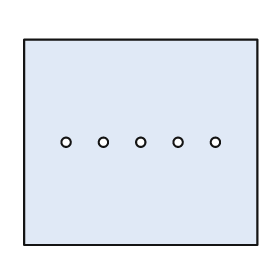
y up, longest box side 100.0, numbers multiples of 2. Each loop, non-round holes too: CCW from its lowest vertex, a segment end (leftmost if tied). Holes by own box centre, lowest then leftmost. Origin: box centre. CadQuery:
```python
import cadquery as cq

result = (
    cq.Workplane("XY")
    .moveTo(-50.0, -44.0)
    .lineTo(50.0, -44.0)
    .lineTo(50.0, 44.0)
    .lineTo(-50.0, 44.0)
    .close()
    .moveTo(-32.0, 0.0)
    .circle(2.0)
    .moveTo(-16.0, 0.0)
    .circle(2.0)
    .moveTo(0.0, 0.0)
    .circle(2.0)
    .moveTo(16.0, 0.0)
    .circle(2.0)
    .moveTo(32.0, 0.0)
    .circle(2.0)
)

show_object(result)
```